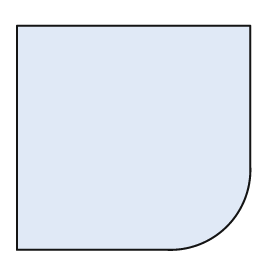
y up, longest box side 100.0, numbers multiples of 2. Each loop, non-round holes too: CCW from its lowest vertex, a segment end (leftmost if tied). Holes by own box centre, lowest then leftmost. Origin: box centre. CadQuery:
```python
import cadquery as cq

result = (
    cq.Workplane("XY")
    .moveTo(-50.0, -48.0)
    .lineTo(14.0, -48.0)
    .threePointArc((40.0, -38.0), (50.0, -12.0))
    .lineTo(50.0, 48.0)
    .lineTo(-50.0, 48.0)
    .close()
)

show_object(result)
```